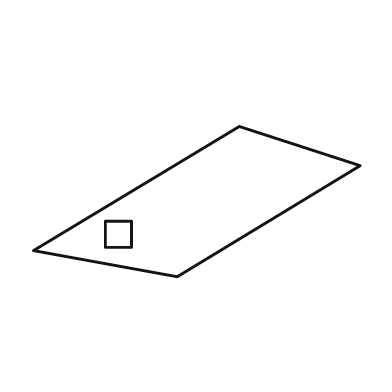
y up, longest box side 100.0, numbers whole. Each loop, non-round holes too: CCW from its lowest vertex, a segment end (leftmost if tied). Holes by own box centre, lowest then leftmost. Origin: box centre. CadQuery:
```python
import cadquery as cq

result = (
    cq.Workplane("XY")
    .moveTo(-6.0, -23.0)
    .lineTo(50.0, 11.0)
    .lineTo(13.0, 23.0)
    .lineTo(-50.0, -15.0)
    .close()
    .moveTo(-28.0, -14.0)
    .lineTo(-20.0, -14.0)
    .lineTo(-20.0, -6.0)
    .lineTo(-28.0, -6.0)
    .close()
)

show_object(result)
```